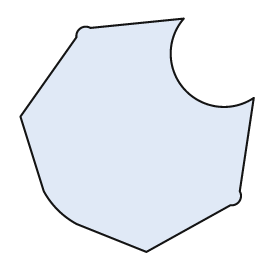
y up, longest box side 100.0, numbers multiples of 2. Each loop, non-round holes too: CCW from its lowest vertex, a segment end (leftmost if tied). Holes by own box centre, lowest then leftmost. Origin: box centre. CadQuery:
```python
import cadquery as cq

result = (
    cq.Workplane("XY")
    .moveTo(4.0, -50.0)
    .lineTo(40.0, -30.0)
    .threePointArc((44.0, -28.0), (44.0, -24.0))
    .lineTo(50.0, 16.0)
    .threePointArc((20.0, 20.0), (20.0, 50.0))
    .lineTo(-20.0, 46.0)
    .threePointArc((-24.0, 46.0), (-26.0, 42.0))
    .lineTo(-50.0, 8.0)
    .lineTo(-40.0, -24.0)
    .threePointArc((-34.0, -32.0), (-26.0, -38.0))
    .close()
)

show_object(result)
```